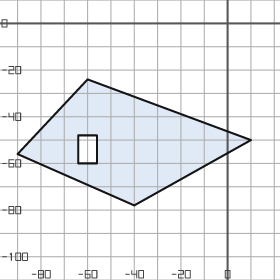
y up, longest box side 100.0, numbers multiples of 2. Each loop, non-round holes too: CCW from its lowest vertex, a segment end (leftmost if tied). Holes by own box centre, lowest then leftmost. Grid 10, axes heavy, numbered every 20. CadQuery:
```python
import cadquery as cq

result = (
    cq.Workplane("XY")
    .moveTo(-40.0, -78.0)
    .lineTo(10.0, -50.0)
    .lineTo(-60.0, -24.0)
    .lineTo(-90.0, -56.0)
    .close()
    .moveTo(-64.0, -60.0)
    .lineTo(-56.0, -60.0)
    .lineTo(-56.0, -48.0)
    .lineTo(-64.0, -48.0)
    .close()
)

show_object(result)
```